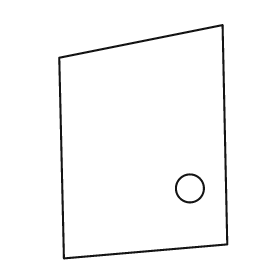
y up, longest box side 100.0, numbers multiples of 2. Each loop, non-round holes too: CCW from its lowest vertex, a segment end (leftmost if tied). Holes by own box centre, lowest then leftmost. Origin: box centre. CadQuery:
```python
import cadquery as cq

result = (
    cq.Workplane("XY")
    .moveTo(-34.0, -50.0)
    .lineTo(36.0, -44.0)
    .lineTo(34.0, 50.0)
    .lineTo(-36.0, 36.0)
    .close()
    .moveTo(20.0, -20.0)
    .circle(6.0)
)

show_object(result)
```